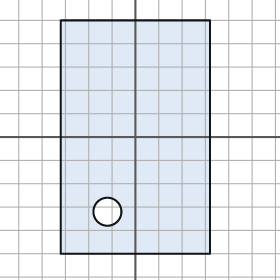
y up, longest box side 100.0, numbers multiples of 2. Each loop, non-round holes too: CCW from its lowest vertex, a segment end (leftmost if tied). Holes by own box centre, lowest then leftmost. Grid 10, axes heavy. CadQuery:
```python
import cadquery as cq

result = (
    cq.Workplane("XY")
    .moveTo(-32.0, -50.0)
    .lineTo(32.0, -50.0)
    .lineTo(32.0, 50.0)
    .lineTo(-32.0, 50.0)
    .close()
    .moveTo(-12.0, -32.0)
    .circle(6.0)
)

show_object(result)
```